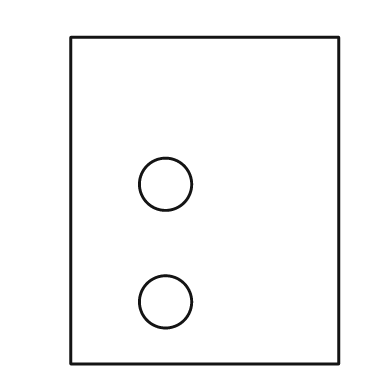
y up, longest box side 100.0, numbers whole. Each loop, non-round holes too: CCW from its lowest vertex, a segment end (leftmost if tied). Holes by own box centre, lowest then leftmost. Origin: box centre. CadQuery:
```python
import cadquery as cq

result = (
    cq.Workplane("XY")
    .moveTo(-41.0, -50.0)
    .lineTo(41.0, -50.0)
    .lineTo(41.0, 50.0)
    .lineTo(-41.0, 50.0)
    .close()
    .moveTo(-12.0, -31.0)
    .circle(8.0)
    .moveTo(-12.0, 5.0)
    .circle(8.0)
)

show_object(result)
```